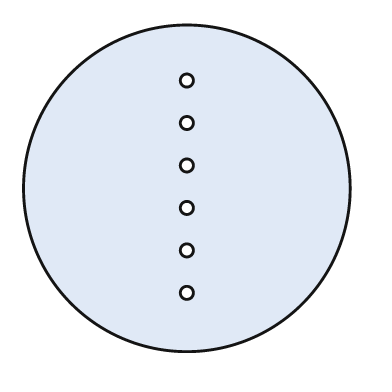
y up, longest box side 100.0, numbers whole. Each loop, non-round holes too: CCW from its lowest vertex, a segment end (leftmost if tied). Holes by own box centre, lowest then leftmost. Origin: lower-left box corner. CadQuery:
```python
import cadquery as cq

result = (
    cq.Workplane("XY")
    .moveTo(50.0, 50.0)
    .circle(50.0)
    .moveTo(50.0, 18.0)
    .circle(2.0)
    .moveTo(50.0, 31.0)
    .circle(2.0)
    .moveTo(50.0, 44.0)
    .circle(2.0)
    .moveTo(50.0, 57.0)
    .circle(2.0)
    .moveTo(50.0, 70.0)
    .circle(2.0)
    .moveTo(50.0, 83.0)
    .circle(2.0)
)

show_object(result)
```